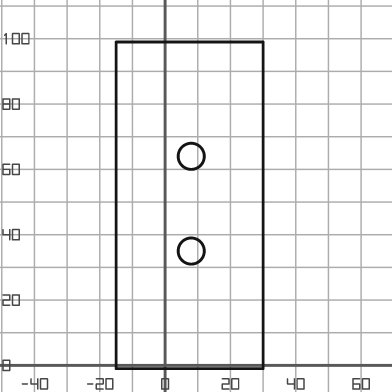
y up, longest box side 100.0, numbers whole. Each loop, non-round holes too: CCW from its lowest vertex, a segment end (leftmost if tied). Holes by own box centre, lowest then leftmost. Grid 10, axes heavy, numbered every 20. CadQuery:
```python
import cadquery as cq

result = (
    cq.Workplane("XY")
    .moveTo(-15.0, -1.0)
    .lineTo(30.0, -1.0)
    .lineTo(30.0, 99.0)
    .lineTo(-15.0, 99.0)
    .close()
    .moveTo(8.0, 35.0)
    .circle(4.0)
    .moveTo(8.0, 64.0)
    .circle(4.0)
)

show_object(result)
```